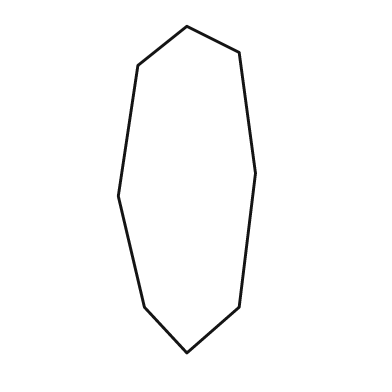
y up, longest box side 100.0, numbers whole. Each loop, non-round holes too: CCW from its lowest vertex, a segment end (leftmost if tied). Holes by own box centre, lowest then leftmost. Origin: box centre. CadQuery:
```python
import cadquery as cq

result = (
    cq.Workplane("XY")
    .moveTo(0.0, -50.0)
    .lineTo(16.0, -36.0)
    .lineTo(21.0, 5.0)
    .lineTo(16.0, 42.0)
    .lineTo(0.0, 50.0)
    .lineTo(-15.0, 38.0)
    .lineTo(-21.0, -2.0)
    .lineTo(-13.0, -36.0)
    .close()
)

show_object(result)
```